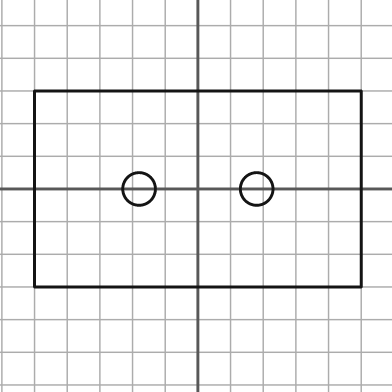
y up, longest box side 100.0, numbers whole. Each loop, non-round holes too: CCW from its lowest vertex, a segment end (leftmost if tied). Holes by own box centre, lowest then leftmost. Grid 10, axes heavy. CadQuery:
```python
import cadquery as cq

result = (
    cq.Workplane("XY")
    .moveTo(-50.0, -30.0)
    .lineTo(50.0, -30.0)
    .lineTo(50.0, 30.0)
    .lineTo(-50.0, 30.0)
    .close()
    .moveTo(-18.0, 0.0)
    .circle(5.0)
    .moveTo(18.0, 0.0)
    .circle(5.0)
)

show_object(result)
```